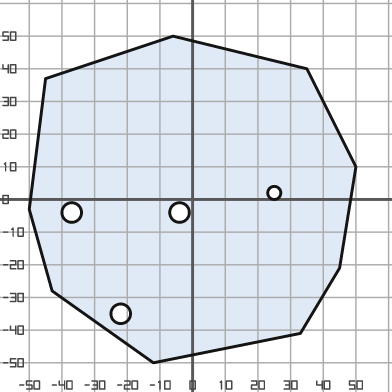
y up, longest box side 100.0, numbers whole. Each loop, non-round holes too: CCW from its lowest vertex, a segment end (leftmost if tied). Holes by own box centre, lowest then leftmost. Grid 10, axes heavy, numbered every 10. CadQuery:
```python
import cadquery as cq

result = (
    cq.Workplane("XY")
    .moveTo(-12.0, -50.0)
    .lineTo(33.0, -41.0)
    .lineTo(45.0, -21.0)
    .lineTo(50.0, 10.0)
    .lineTo(35.0, 40.0)
    .lineTo(-6.0, 50.0)
    .lineTo(-45.0, 37.0)
    .lineTo(-50.0, -3.0)
    .lineTo(-43.0, -28.0)
    .close()
    .moveTo(-22.0, -35.0)
    .circle(3.0)
    .moveTo(-37.0, -4.0)
    .circle(3.0)
    .moveTo(-4.0, -4.0)
    .circle(3.0)
    .moveTo(25.0, 2.0)
    .circle(2.0)
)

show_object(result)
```